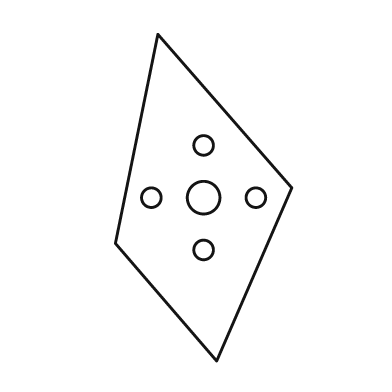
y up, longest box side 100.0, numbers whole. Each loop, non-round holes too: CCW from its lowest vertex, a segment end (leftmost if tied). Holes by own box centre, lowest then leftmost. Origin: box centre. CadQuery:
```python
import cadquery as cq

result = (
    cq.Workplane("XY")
    .moveTo(4.0, -50.0)
    .lineTo(27.0, 3.0)
    .lineTo(-14.0, 50.0)
    .lineTo(-27.0, -14.0)
    .close()
    .moveTo(0.0, -16.0)
    .circle(3.0)
    .moveTo(-16.0, 0.0)
    .circle(3.0)
    .moveTo(0.0, 0.0)
    .circle(5.0)
    .moveTo(16.0, 0.0)
    .circle(3.0)
    .moveTo(0.0, 16.0)
    .circle(3.0)
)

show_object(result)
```